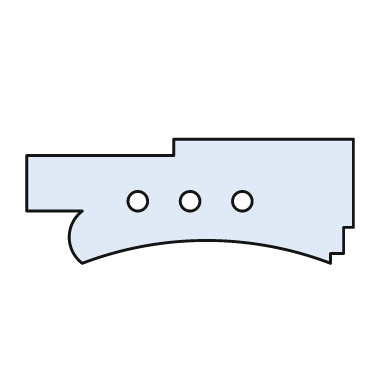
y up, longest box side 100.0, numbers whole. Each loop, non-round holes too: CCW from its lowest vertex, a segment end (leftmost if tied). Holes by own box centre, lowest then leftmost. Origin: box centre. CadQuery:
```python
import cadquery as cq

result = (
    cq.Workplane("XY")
    .moveTo(-33.0, -19.0)
    .threePointArc((5.0, -12.0), (43.0, -19.0))
    .lineTo(43.0, -16.0)
    .lineTo(47.0, -16.0)
    .lineTo(47.0, -8.0)
    .lineTo(50.0, -8.0)
    .lineTo(50.0, 19.0)
    .lineTo(-5.0, 19.0)
    .lineTo(-5.0, 14.0)
    .lineTo(-50.0, 14.0)
    .lineTo(-50.0, -3.0)
    .lineTo(-33.0, -3.0)
    .threePointArc((-37.0, -11.0), (-33.0, -19.0))
    .close()
    .moveTo(-16.0, 0.0)
    .circle(3.0)
    .moveTo(0.0, 0.0)
    .circle(3.0)
    .moveTo(16.0, 0.0)
    .circle(3.0)
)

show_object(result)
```